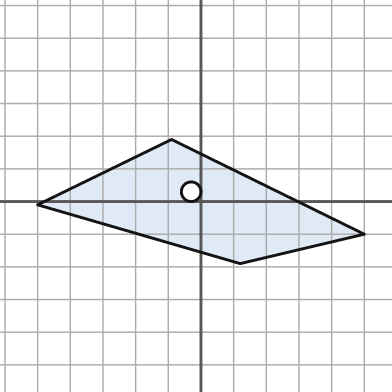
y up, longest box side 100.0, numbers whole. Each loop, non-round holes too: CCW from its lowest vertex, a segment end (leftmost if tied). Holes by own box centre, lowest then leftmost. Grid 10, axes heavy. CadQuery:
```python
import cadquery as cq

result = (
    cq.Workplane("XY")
    .moveTo(12.0, -19.0)
    .lineTo(50.0, -10.0)
    .lineTo(-9.0, 19.0)
    .lineTo(-50.0, -1.0)
    .close()
    .moveTo(-3.0, 3.0)
    .circle(3.0)
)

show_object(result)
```